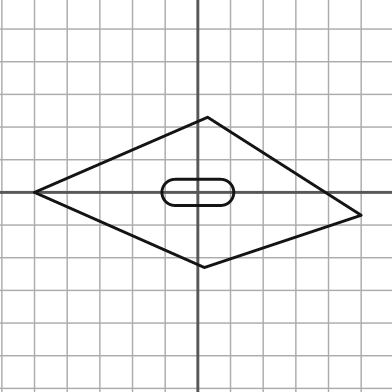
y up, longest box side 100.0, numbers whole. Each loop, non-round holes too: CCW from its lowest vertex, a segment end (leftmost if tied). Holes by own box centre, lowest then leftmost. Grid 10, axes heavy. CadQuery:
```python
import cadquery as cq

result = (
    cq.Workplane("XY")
    .moveTo(2.0, -23.0)
    .lineTo(50.0, -7.0)
    .lineTo(3.0, 23.0)
    .lineTo(-50.0, 0.0)
    .close()
    .moveTo(-7.0, -4.0)
    .lineTo(7.0, -4.0)
    .threePointArc((11.0, 0.0), (7.0, 4.0))
    .lineTo(-7.0, 4.0)
    .threePointArc((-11.0, 0.0), (-7.0, -4.0))
    .close()
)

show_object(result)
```